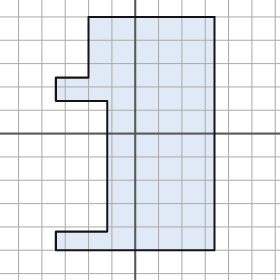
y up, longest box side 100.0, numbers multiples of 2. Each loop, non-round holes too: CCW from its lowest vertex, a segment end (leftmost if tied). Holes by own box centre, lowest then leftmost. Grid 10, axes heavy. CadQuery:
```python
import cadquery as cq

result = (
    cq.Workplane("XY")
    .moveTo(-34.0, -50.0)
    .lineTo(34.0, -50.0)
    .lineTo(34.0, 50.0)
    .lineTo(-20.0, 50.0)
    .lineTo(-20.0, 24.0)
    .lineTo(-34.0, 24.0)
    .lineTo(-34.0, 14.0)
    .lineTo(-12.0, 14.0)
    .lineTo(-12.0, -42.0)
    .lineTo(-34.0, -42.0)
    .close()
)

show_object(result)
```